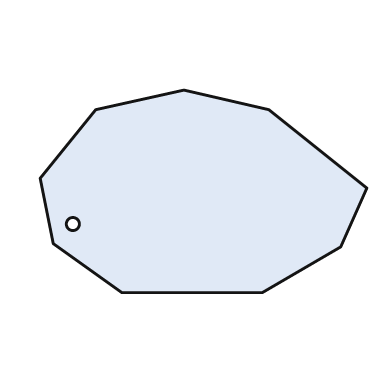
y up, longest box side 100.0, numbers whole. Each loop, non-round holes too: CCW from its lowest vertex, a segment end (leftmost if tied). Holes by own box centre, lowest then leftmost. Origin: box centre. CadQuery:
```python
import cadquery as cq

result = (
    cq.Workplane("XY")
    .moveTo(-25.0, -31.0)
    .lineTo(18.0, -31.0)
    .lineTo(42.0, -17.0)
    .lineTo(50.0, 1.0)
    .lineTo(20.0, 25.0)
    .lineTo(-6.0, 31.0)
    .lineTo(-33.0, 25.0)
    .lineTo(-50.0, 4.0)
    .lineTo(-46.0, -16.0)
    .close()
    .moveTo(-40.0, -10.0)
    .circle(2.0)
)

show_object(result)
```